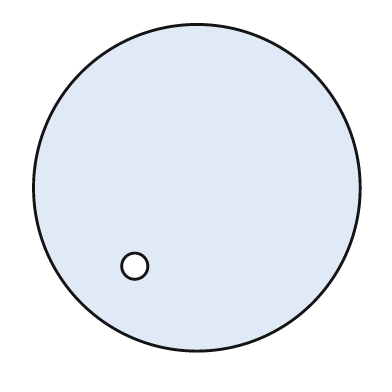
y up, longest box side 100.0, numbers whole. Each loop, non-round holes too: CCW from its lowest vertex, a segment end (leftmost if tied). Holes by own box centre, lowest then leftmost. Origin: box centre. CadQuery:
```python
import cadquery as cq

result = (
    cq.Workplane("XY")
    .moveTo(0.0, 0.0)
    .circle(50.0)
    .moveTo(-19.0, -24.0)
    .circle(4.0)
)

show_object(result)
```